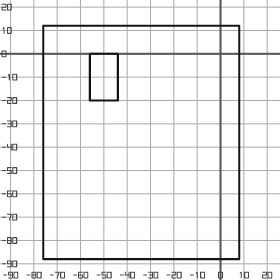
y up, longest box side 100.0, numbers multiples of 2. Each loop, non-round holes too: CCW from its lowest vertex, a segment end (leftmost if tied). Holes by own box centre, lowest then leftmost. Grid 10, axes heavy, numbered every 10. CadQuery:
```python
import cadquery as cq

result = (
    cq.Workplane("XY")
    .moveTo(-76.0, -88.0)
    .lineTo(8.0, -88.0)
    .lineTo(8.0, 12.0)
    .lineTo(-76.0, 12.0)
    .close()
    .moveTo(-56.0, -20.0)
    .lineTo(-44.0, -20.0)
    .lineTo(-44.0, 0.0)
    .lineTo(-56.0, 0.0)
    .close()
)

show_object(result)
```